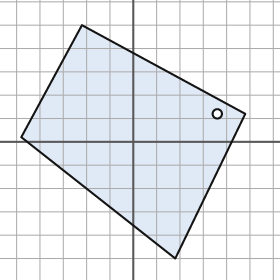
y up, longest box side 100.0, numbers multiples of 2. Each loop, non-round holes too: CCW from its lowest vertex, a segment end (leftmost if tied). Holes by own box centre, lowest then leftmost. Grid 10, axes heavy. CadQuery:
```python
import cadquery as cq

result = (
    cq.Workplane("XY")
    .moveTo(18.0, -50.0)
    .lineTo(48.0, 12.0)
    .lineTo(-22.0, 50.0)
    .lineTo(-48.0, 2.0)
    .close()
    .moveTo(36.0, 12.0)
    .circle(2.0)
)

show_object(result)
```